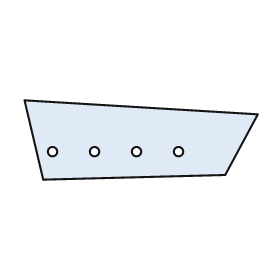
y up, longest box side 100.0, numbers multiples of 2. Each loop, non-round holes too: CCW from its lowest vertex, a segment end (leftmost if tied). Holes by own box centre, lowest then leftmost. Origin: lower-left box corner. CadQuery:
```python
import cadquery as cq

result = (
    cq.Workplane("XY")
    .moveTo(8.0, 0.0)
    .lineTo(86.0, 2.0)
    .lineTo(100.0, 28.0)
    .lineTo(0.0, 34.0)
    .close()
    .moveTo(12.0, 12.0)
    .circle(2.0)
    .moveTo(30.0, 12.0)
    .circle(2.0)
    .moveTo(48.0, 12.0)
    .circle(2.0)
    .moveTo(66.0, 12.0)
    .circle(2.0)
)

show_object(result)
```